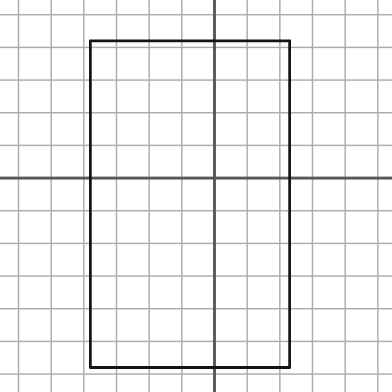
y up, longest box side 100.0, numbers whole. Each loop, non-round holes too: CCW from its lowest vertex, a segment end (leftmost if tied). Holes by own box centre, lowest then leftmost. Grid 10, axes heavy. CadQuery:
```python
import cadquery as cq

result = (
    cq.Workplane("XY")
    .moveTo(-38.0, -58.0)
    .lineTo(23.0, -58.0)
    .lineTo(23.0, 42.0)
    .lineTo(-38.0, 42.0)
    .close()
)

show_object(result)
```